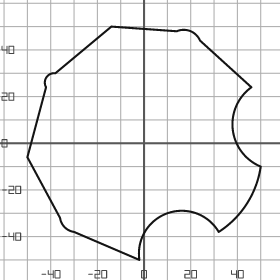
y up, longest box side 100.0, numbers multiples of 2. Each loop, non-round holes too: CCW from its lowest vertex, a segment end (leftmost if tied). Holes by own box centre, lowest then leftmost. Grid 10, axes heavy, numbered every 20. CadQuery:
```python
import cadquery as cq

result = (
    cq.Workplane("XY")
    .moveTo(-2.0, -50.0)
    .threePointArc((10.0, -30.0), (32.0, -38.0))
    .threePointArc((44.0, -26.0), (50.0, -10.0))
    .threePointArc((38.0, 6.0), (46.0, 24.0))
    .lineTo(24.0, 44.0)
    .threePointArc((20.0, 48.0), (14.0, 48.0))
    .lineTo(-14.0, 50.0)
    .lineTo(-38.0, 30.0)
    .threePointArc((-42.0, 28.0), (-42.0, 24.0))
    .lineTo(-50.0, -6.0)
    .lineTo(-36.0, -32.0)
    .threePointArc((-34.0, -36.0), (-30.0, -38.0))
    .close()
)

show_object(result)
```